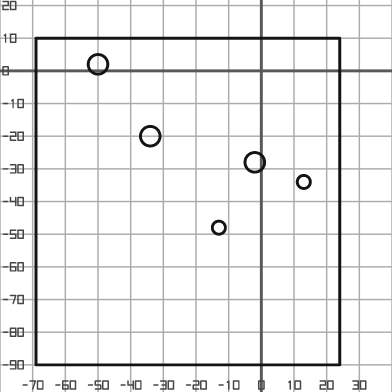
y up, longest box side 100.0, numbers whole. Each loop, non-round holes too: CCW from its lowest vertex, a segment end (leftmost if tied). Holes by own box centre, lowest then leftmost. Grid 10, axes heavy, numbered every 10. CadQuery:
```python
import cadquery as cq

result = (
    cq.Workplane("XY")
    .moveTo(-69.0, -90.0)
    .lineTo(24.0, -90.0)
    .lineTo(24.0, 10.0)
    .lineTo(-69.0, 10.0)
    .close()
    .moveTo(-13.0, -48.0)
    .circle(2.0)
    .moveTo(13.0, -34.0)
    .circle(2.0)
    .moveTo(-2.0, -28.0)
    .circle(3.0)
    .moveTo(-34.0, -20.0)
    .circle(3.0)
    .moveTo(-50.0, 2.0)
    .circle(3.0)
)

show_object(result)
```